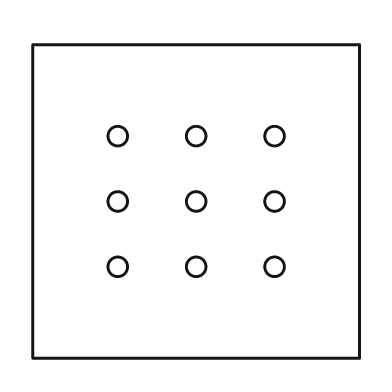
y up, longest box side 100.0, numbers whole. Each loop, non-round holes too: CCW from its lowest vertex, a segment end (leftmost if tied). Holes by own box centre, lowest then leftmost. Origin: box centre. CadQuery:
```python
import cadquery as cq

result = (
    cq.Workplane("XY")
    .moveTo(-50.0, -48.0)
    .lineTo(50.0, -48.0)
    .lineTo(50.0, 48.0)
    .lineTo(-50.0, 48.0)
    .close()
    .moveTo(-24.0, -20.0)
    .circle(3.0)
    .moveTo(0.0, -20.0)
    .circle(3.0)
    .moveTo(24.0, -20.0)
    .circle(3.0)
    .moveTo(-24.0, 0.0)
    .circle(3.0)
    .moveTo(0.0, 0.0)
    .circle(3.0)
    .moveTo(24.0, 0.0)
    .circle(3.0)
    .moveTo(-24.0, 20.0)
    .circle(3.0)
    .moveTo(0.0, 20.0)
    .circle(3.0)
    .moveTo(24.0, 20.0)
    .circle(3.0)
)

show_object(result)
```